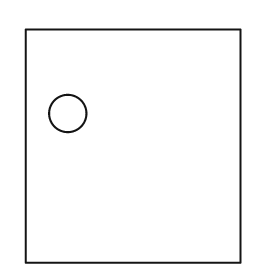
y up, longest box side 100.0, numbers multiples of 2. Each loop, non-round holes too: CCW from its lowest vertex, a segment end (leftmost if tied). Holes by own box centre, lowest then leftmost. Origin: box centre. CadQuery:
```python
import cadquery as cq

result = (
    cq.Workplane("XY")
    .moveTo(-46.0, -50.0)
    .lineTo(46.0, -50.0)
    .lineTo(46.0, 50.0)
    .lineTo(-46.0, 50.0)
    .close()
    .moveTo(-28.0, 14.0)
    .circle(8.0)
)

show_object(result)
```